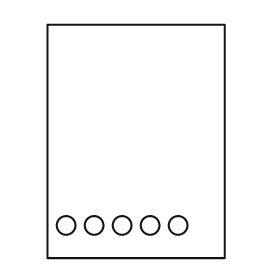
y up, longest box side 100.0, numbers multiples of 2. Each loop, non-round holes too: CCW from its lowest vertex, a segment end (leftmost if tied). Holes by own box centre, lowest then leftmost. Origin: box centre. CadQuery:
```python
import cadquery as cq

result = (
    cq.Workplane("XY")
    .moveTo(-38.0, -50.0)
    .lineTo(38.0, -50.0)
    .lineTo(38.0, 50.0)
    .lineTo(-38.0, 50.0)
    .close()
    .moveTo(-30.0, -36.0)
    .circle(4.0)
    .moveTo(-18.0, -36.0)
    .circle(4.0)
    .moveTo(-6.0, -36.0)
    .circle(4.0)
    .moveTo(6.0, -36.0)
    .circle(4.0)
    .moveTo(18.0, -36.0)
    .circle(4.0)
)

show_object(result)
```